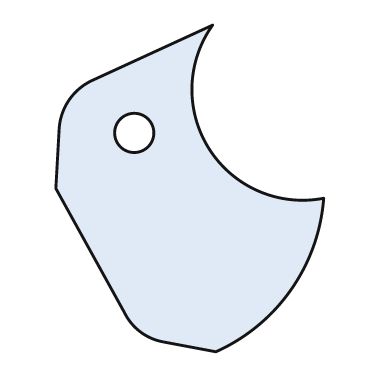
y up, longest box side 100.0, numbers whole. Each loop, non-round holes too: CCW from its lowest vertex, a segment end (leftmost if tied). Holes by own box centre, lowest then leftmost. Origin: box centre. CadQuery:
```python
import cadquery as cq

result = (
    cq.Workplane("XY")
    .moveTo(8.0, -50.0)
    .threePointArc((31.0, -31.0), (41.0, -3.0))
    .threePointArc((6.0, 12.0), (7.0, 50.0))
    .lineTo(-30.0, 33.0)
    .threePointArc((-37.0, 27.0), (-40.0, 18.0))
    .lineTo(-41.0, 0.0)
    .lineTo(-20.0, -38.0)
    .threePointArc((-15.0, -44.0), (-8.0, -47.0))
    .close()
    .moveTo(-17.0, 17.0)
    .circle(6.0)
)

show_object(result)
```